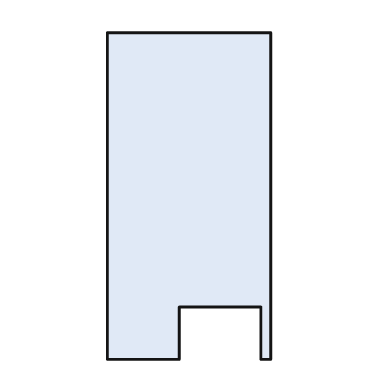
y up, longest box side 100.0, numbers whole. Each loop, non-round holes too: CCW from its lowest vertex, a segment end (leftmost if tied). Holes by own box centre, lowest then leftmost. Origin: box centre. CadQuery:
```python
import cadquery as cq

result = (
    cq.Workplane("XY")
    .moveTo(-25.0, -50.0)
    .lineTo(-3.0, -50.0)
    .lineTo(-3.0, -34.0)
    .lineTo(22.0, -34.0)
    .lineTo(22.0, -50.0)
    .lineTo(25.0, -50.0)
    .lineTo(25.0, 50.0)
    .lineTo(-25.0, 50.0)
    .close()
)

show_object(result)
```